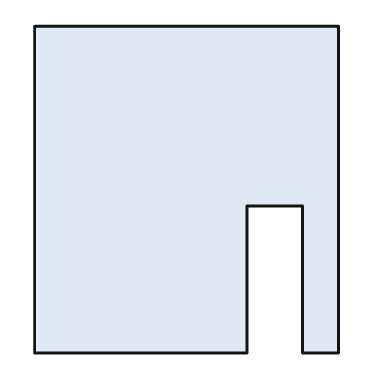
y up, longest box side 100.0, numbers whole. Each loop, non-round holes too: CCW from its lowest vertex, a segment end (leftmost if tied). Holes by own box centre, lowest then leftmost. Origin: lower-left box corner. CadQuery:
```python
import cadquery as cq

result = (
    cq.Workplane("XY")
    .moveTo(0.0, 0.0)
    .lineTo(65.0, 0.0)
    .lineTo(65.0, 45.0)
    .lineTo(82.0, 45.0)
    .lineTo(82.0, 0.0)
    .lineTo(93.0, 0.0)
    .lineTo(93.0, 100.0)
    .lineTo(0.0, 100.0)
    .close()
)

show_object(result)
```